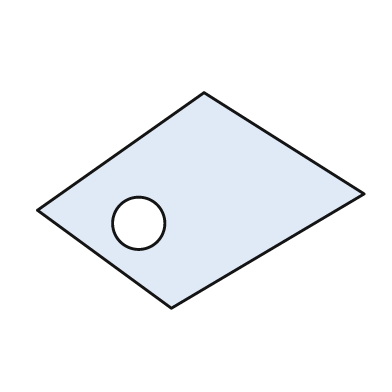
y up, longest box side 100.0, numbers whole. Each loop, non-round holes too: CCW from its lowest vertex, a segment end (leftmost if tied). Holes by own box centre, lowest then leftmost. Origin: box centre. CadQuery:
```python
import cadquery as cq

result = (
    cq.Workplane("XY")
    .moveTo(-9.0, -33.0)
    .lineTo(50.0, 2.0)
    .lineTo(1.0, 33.0)
    .lineTo(-50.0, -3.0)
    .close()
    .moveTo(-19.0, -7.0)
    .circle(8.0)
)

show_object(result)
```